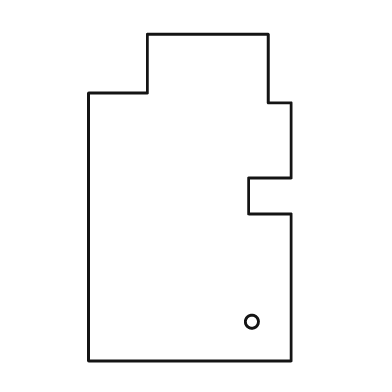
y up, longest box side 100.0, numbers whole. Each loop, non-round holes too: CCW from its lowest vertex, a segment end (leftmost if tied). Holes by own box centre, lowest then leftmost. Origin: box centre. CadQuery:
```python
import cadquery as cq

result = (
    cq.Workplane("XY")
    .moveTo(-31.0, -50.0)
    .lineTo(31.0, -50.0)
    .lineTo(31.0, -5.0)
    .lineTo(18.0, -5.0)
    .lineTo(18.0, 6.0)
    .lineTo(31.0, 6.0)
    .lineTo(31.0, 29.0)
    .lineTo(24.0, 29.0)
    .lineTo(24.0, 50.0)
    .lineTo(-13.0, 50.0)
    .lineTo(-13.0, 32.0)
    .lineTo(-31.0, 32.0)
    .close()
    .moveTo(19.0, -38.0)
    .circle(2.0)
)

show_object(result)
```